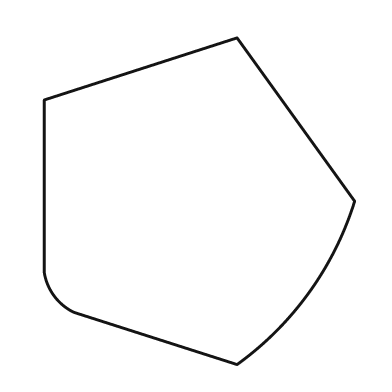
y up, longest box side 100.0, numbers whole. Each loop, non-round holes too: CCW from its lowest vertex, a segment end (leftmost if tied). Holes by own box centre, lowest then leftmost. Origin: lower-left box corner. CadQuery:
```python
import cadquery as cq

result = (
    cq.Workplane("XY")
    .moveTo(59.0, 0.0)
    .threePointArc((81.0, 22.0), (95.0, 50.0))
    .lineTo(59.0, 100.0)
    .lineTo(0.0, 81.0)
    .lineTo(0.0, 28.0)
    .threePointArc((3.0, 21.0), (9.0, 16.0))
    .close()
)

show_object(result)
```